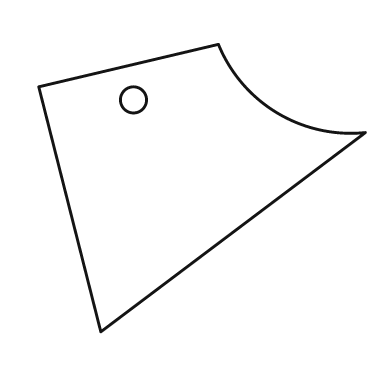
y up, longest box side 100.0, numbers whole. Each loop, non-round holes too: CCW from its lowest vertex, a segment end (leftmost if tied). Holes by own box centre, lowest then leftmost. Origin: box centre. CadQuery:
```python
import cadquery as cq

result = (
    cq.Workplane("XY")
    .moveTo(-31.0, -44.0)
    .lineTo(50.0, 17.0)
    .threePointArc((23.0, 23.0), (5.0, 44.0))
    .lineTo(-50.0, 31.0)
    .close()
    .moveTo(-21.0, 27.0)
    .circle(4.0)
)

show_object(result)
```